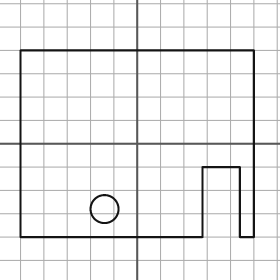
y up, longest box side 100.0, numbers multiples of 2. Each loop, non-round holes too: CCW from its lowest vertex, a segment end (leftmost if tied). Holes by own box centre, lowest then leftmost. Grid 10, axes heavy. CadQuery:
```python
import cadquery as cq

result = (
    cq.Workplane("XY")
    .moveTo(-50.0, -40.0)
    .lineTo(28.0, -40.0)
    .lineTo(28.0, -10.0)
    .lineTo(44.0, -10.0)
    .lineTo(44.0, -40.0)
    .lineTo(50.0, -40.0)
    .lineTo(50.0, 40.0)
    .lineTo(-50.0, 40.0)
    .close()
    .moveTo(-14.0, -28.0)
    .circle(6.0)
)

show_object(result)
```